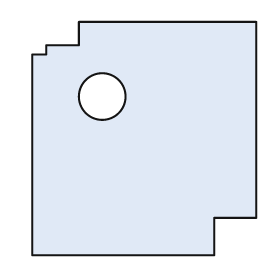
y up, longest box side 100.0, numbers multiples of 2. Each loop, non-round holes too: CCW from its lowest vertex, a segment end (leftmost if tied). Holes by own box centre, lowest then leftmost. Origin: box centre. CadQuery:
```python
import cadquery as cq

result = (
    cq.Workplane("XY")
    .moveTo(-48.0, -50.0)
    .lineTo(30.0, -50.0)
    .lineTo(30.0, -34.0)
    .lineTo(48.0, -34.0)
    .lineTo(48.0, 50.0)
    .lineTo(-28.0, 50.0)
    .lineTo(-28.0, 40.0)
    .lineTo(-42.0, 40.0)
    .lineTo(-42.0, 36.0)
    .lineTo(-48.0, 36.0)
    .close()
    .moveTo(-18.0, 18.0)
    .circle(10.0)
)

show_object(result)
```